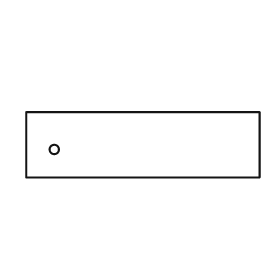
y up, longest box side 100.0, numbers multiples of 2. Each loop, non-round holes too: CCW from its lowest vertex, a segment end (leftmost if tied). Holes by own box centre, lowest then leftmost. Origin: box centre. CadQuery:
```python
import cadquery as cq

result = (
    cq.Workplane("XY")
    .moveTo(-50.0, -14.0)
    .lineTo(50.0, -14.0)
    .lineTo(50.0, 14.0)
    .lineTo(-50.0, 14.0)
    .close()
    .moveTo(-38.0, -2.0)
    .circle(2.0)
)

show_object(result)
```